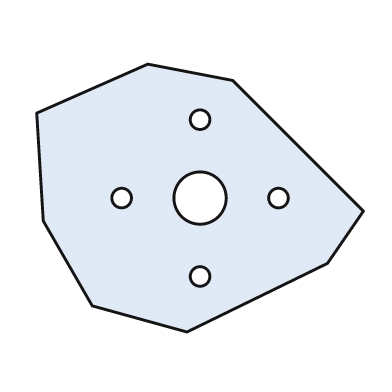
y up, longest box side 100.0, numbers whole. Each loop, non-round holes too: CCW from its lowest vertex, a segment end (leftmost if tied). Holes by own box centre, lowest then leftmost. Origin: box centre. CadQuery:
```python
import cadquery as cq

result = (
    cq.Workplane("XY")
    .moveTo(-4.0, -41.0)
    .lineTo(39.0, -20.0)
    .lineTo(50.0, -4.0)
    .lineTo(10.0, 36.0)
    .lineTo(-16.0, 41.0)
    .lineTo(-50.0, 26.0)
    .lineTo(-48.0, -7.0)
    .lineTo(-33.0, -33.0)
    .close()
    .moveTo(0.0, -24.0)
    .circle(3.0)
    .moveTo(-24.0, 0.0)
    .circle(3.0)
    .moveTo(0.0, 0.0)
    .circle(8.0)
    .moveTo(24.0, 0.0)
    .circle(3.0)
    .moveTo(0.0, 24.0)
    .circle(3.0)
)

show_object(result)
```